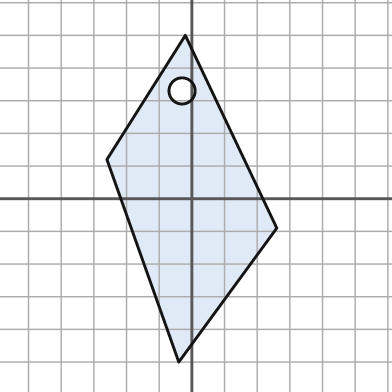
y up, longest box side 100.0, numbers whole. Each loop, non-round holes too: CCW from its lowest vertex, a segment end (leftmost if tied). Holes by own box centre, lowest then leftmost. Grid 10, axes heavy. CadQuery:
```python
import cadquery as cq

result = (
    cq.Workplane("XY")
    .moveTo(-4.0, -50.0)
    .lineTo(26.0, -9.0)
    .lineTo(-2.0, 50.0)
    .lineTo(-26.0, 12.0)
    .close()
    .moveTo(-3.0, 33.0)
    .circle(4.0)
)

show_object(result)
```